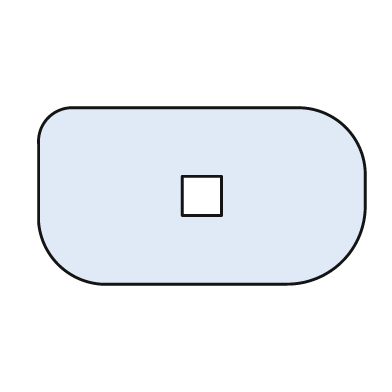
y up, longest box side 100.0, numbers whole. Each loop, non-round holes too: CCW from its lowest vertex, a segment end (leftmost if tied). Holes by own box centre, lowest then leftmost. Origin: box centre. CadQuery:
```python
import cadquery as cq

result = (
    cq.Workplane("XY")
    .moveTo(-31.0, -27.0)
    .lineTo(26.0, -27.0)
    .threePointArc((43.0, -20.0), (50.0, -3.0))
    .lineTo(50.0, 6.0)
    .threePointArc((44.0, 21.0), (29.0, 27.0))
    .lineTo(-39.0, 27.0)
    .threePointArc((-47.0, 24.0), (-50.0, 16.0))
    .lineTo(-50.0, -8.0)
    .threePointArc((-44.0, -21.0), (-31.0, -27.0))
    .close()
    .moveTo(-6.0, -6.0)
    .lineTo(6.0, -6.0)
    .lineTo(6.0, 6.0)
    .lineTo(-6.0, 6.0)
    .close()
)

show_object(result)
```